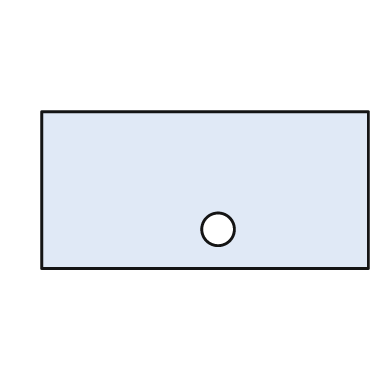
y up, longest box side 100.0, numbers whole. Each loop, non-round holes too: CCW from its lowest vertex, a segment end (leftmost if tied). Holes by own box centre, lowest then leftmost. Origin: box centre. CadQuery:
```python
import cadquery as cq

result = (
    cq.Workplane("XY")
    .moveTo(-50.0, -24.0)
    .lineTo(50.0, -24.0)
    .lineTo(50.0, 24.0)
    .lineTo(-50.0, 24.0)
    .close()
    .moveTo(4.0, -12.0)
    .circle(5.0)
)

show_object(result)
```